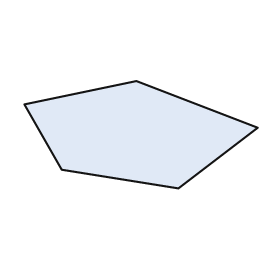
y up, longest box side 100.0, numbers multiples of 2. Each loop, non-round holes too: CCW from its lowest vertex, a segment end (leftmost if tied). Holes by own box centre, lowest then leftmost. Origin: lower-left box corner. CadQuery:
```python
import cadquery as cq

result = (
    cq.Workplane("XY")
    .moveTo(66.0, 0.0)
    .lineTo(100.0, 26.0)
    .lineTo(48.0, 46.0)
    .lineTo(0.0, 36.0)
    .lineTo(16.0, 8.0)
    .close()
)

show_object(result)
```